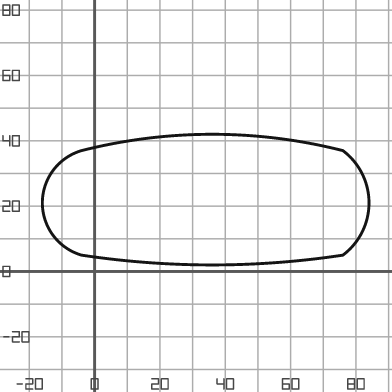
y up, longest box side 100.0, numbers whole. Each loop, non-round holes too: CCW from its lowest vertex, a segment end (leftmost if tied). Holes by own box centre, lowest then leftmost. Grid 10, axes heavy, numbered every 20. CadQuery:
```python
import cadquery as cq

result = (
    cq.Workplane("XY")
    .moveTo(-4.0, 5.0)
    .threePointArc((36.0, 2.0), (76.0, 5.0))
    .threePointArc((84.0, 21.0), (76.0, 37.0))
    .threePointArc((36.0, 42.0), (-4.0, 37.0))
    .threePointArc((-16.0, 21.0), (-4.0, 5.0))
    .close()
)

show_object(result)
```